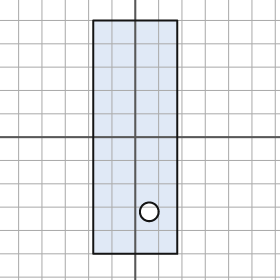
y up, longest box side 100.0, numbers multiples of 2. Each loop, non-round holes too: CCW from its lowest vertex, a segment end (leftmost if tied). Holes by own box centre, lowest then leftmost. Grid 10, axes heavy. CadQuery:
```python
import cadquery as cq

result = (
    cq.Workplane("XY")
    .moveTo(-18.0, -50.0)
    .lineTo(18.0, -50.0)
    .lineTo(18.0, 50.0)
    .lineTo(-18.0, 50.0)
    .close()
    .moveTo(6.0, -32.0)
    .circle(4.0)
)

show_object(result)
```